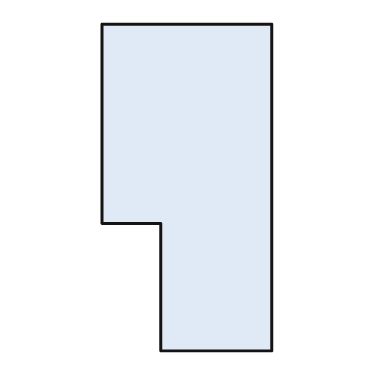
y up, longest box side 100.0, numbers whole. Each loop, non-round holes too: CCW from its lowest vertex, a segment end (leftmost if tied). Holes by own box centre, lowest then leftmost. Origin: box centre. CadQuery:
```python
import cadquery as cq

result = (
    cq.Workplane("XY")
    .moveTo(-8.0, -50.0)
    .lineTo(26.0, -50.0)
    .lineTo(26.0, 50.0)
    .lineTo(-26.0, 50.0)
    .lineTo(-26.0, -11.0)
    .lineTo(-8.0, -11.0)
    .close()
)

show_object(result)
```